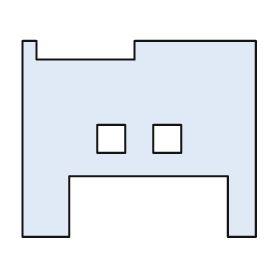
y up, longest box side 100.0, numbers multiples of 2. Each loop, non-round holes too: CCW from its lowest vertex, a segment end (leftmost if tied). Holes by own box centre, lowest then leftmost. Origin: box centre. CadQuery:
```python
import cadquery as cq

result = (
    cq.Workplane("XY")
    .moveTo(-50.0, -42.0)
    .lineTo(-30.0, -42.0)
    .lineTo(-30.0, -16.0)
    .lineTo(38.0, -16.0)
    .lineTo(38.0, -42.0)
    .lineTo(50.0, -42.0)
    .lineTo(50.0, 42.0)
    .lineTo(-2.0, 42.0)
    .lineTo(-2.0, 34.0)
    .lineTo(-44.0, 34.0)
    .lineTo(-44.0, 42.0)
    .lineTo(-50.0, 42.0)
    .close()
    .moveTo(-18.0, -6.0)
    .lineTo(-6.0, -6.0)
    .lineTo(-6.0, 6.0)
    .lineTo(-18.0, 6.0)
    .close()
    .moveTo(6.0, -6.0)
    .lineTo(18.0, -6.0)
    .lineTo(18.0, 6.0)
    .lineTo(6.0, 6.0)
    .close()
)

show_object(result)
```